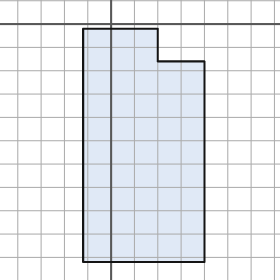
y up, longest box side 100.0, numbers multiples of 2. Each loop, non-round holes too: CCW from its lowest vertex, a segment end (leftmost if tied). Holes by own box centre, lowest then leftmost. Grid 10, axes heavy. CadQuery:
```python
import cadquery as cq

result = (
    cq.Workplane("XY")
    .moveTo(-12.0, -102.0)
    .lineTo(40.0, -102.0)
    .lineTo(40.0, -16.0)
    .lineTo(20.0, -16.0)
    .lineTo(20.0, -2.0)
    .lineTo(-12.0, -2.0)
    .close()
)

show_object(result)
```